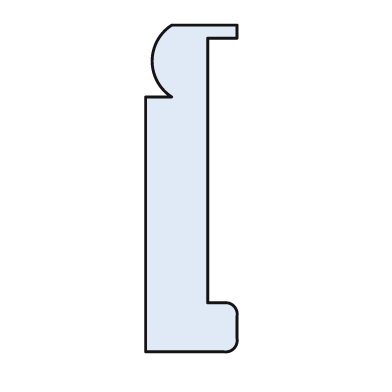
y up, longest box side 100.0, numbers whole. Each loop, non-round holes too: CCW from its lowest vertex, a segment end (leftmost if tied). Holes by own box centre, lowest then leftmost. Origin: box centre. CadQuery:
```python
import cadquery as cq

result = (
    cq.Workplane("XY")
    .moveTo(-14.0, -50.0)
    .lineTo(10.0, -50.0)
    .threePointArc((13.0, -49.0), (14.0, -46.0))
    .lineTo(14.0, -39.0)
    .threePointArc((13.0, -36.0), (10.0, -35.0))
    .lineTo(5.0, -35.0)
    .lineTo(5.0, 46.0)
    .lineTo(14.0, 46.0)
    .lineTo(14.0, 50.0)
    .lineTo(-6.0, 50.0)
    .threePointArc((-12.0, 39.0), (-6.0, 28.0))
    .lineTo(-14.0, 28.0)
    .close()
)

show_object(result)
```